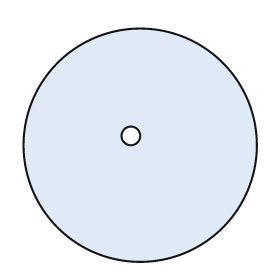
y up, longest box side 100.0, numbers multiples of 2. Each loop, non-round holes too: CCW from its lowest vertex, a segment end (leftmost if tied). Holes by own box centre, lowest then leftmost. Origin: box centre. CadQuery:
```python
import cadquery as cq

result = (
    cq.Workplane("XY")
    .moveTo(0.0, 0.0)
    .circle(50.0)
    .moveTo(-4.0, 4.0)
    .circle(4.0)
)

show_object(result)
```